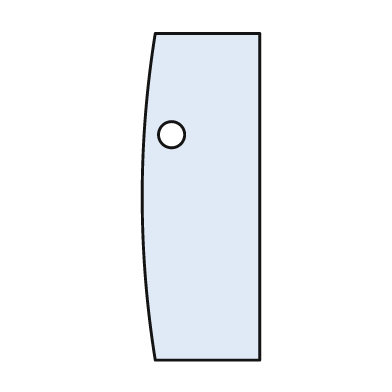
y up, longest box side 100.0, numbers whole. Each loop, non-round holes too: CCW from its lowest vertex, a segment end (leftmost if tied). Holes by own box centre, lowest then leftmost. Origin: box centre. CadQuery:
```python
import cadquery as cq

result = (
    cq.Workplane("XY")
    .moveTo(-14.0, -50.0)
    .lineTo(18.0, -50.0)
    .lineTo(18.0, 50.0)
    .lineTo(-14.0, 50.0)
    .threePointArc((-18.0, 0.0), (-14.0, -50.0))
    .close()
    .moveTo(-9.0, 19.0)
    .circle(4.0)
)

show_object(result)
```